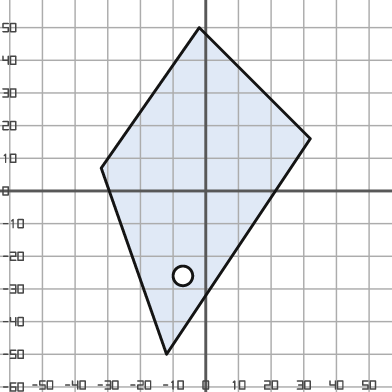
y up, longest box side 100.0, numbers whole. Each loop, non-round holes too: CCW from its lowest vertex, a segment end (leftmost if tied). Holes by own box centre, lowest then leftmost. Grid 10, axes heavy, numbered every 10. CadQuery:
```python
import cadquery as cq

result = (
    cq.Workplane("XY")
    .moveTo(-12.0, -50.0)
    .lineTo(32.0, 16.0)
    .lineTo(-2.0, 50.0)
    .lineTo(-32.0, 7.0)
    .close()
    .moveTo(-7.0, -26.0)
    .circle(3.0)
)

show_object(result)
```